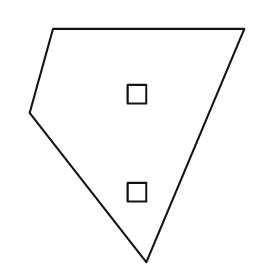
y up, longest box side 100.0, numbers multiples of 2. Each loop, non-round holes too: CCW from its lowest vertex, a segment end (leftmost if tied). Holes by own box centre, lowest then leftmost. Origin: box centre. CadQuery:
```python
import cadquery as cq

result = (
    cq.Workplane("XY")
    .moveTo(4.0, -50.0)
    .lineTo(46.0, 50.0)
    .lineTo(-36.0, 50.0)
    .lineTo(-46.0, 14.0)
    .close()
    .moveTo(-4.0, -24.0)
    .lineTo(4.0, -24.0)
    .lineTo(4.0, -16.0)
    .lineTo(-4.0, -16.0)
    .close()
    .moveTo(-4.0, 18.0)
    .lineTo(4.0, 18.0)
    .lineTo(4.0, 26.0)
    .lineTo(-4.0, 26.0)
    .close()
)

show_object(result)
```